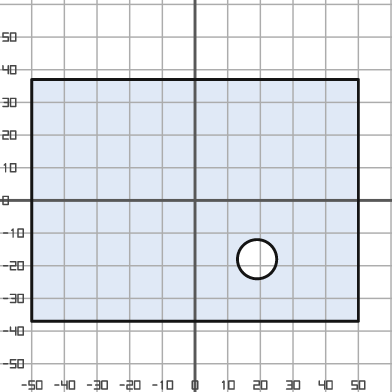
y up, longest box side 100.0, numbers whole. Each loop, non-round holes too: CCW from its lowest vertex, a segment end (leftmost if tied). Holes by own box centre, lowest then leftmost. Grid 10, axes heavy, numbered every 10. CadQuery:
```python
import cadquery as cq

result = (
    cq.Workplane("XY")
    .moveTo(-50.0, -37.0)
    .lineTo(50.0, -37.0)
    .lineTo(50.0, 37.0)
    .lineTo(-50.0, 37.0)
    .close()
    .moveTo(19.0, -18.0)
    .circle(6.0)
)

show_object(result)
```